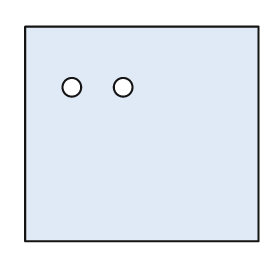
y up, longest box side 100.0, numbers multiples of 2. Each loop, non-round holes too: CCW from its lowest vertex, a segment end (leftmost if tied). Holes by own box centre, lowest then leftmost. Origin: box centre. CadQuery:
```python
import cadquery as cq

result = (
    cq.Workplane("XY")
    .moveTo(-50.0, -46.0)
    .lineTo(50.0, -46.0)
    .lineTo(50.0, 46.0)
    .lineTo(-50.0, 46.0)
    .close()
    .moveTo(-30.0, 20.0)
    .circle(4.0)
    .moveTo(-8.0, 20.0)
    .circle(4.0)
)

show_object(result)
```